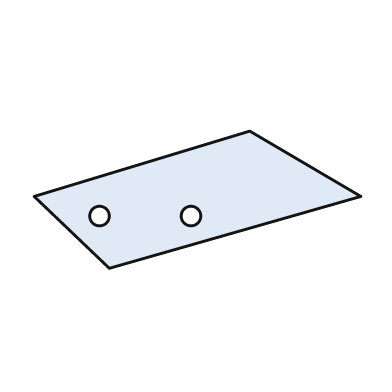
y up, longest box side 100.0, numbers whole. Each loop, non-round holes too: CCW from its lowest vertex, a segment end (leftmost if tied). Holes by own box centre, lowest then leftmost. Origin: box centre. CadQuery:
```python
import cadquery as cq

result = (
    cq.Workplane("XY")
    .moveTo(-27.0, -21.0)
    .lineTo(50.0, 1.0)
    .lineTo(16.0, 21.0)
    .lineTo(-50.0, 1.0)
    .close()
    .moveTo(-30.0, -5.0)
    .circle(3.0)
    .moveTo(-2.0, -5.0)
    .circle(3.0)
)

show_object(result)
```